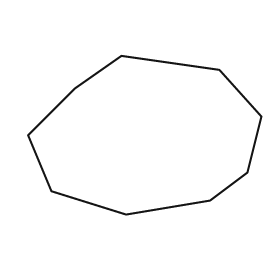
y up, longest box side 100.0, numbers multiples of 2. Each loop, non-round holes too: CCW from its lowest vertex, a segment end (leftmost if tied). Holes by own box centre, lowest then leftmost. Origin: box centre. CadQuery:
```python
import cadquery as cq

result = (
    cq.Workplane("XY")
    .moveTo(-8.0, -34.0)
    .lineTo(28.0, -28.0)
    .lineTo(44.0, -16.0)
    .lineTo(50.0, 8.0)
    .lineTo(32.0, 28.0)
    .lineTo(-10.0, 34.0)
    .lineTo(-30.0, 20.0)
    .lineTo(-50.0, 0.0)
    .lineTo(-40.0, -24.0)
    .close()
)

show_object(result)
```